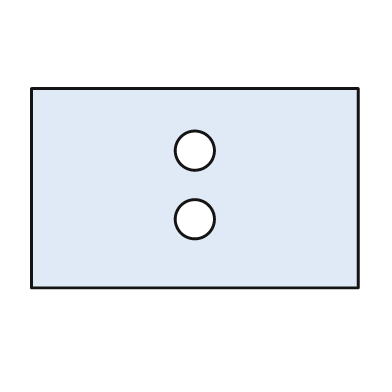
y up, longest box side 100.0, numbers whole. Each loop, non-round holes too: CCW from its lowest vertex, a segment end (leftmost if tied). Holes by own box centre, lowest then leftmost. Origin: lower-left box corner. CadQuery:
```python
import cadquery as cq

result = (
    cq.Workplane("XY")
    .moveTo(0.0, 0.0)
    .lineTo(100.0, 0.0)
    .lineTo(100.0, 61.0)
    .lineTo(0.0, 61.0)
    .close()
    .moveTo(50.0, 21.0)
    .circle(6.0)
    .moveTo(50.0, 42.0)
    .circle(6.0)
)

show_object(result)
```